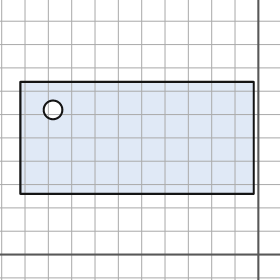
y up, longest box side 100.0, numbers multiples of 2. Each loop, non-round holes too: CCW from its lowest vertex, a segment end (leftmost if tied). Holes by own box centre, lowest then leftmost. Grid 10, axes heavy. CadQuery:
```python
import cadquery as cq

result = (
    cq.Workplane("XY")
    .moveTo(-102.0, 26.0)
    .lineTo(-2.0, 26.0)
    .lineTo(-2.0, 74.0)
    .lineTo(-102.0, 74.0)
    .close()
    .moveTo(-88.0, 62.0)
    .circle(4.0)
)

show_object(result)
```